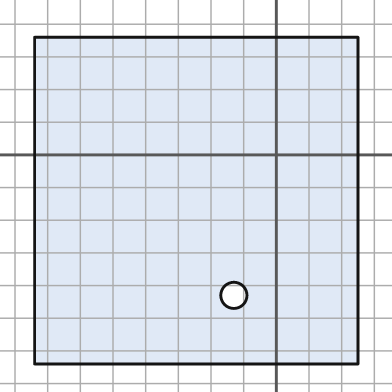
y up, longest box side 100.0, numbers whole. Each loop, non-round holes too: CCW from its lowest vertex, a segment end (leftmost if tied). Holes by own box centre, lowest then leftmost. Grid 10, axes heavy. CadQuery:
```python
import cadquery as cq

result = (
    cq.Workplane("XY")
    .moveTo(-74.0, -64.0)
    .lineTo(25.0, -64.0)
    .lineTo(25.0, 36.0)
    .lineTo(-74.0, 36.0)
    .close()
    .moveTo(-13.0, -43.0)
    .circle(4.0)
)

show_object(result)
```